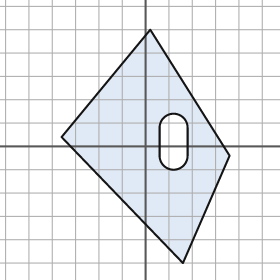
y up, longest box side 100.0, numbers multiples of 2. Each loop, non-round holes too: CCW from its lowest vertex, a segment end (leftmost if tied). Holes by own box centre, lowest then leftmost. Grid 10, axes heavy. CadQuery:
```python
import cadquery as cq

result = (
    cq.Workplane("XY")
    .moveTo(16.0, -50.0)
    .lineTo(36.0, -4.0)
    .lineTo(2.0, 50.0)
    .lineTo(-36.0, 4.0)
    .close()
    .moveTo(6.0, -4.0)
    .threePointArc((12.0, -10.0), (18.0, -4.0))
    .lineTo(18.0, 8.0)
    .threePointArc((12.0, 14.0), (6.0, 8.0))
    .close()
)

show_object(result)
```